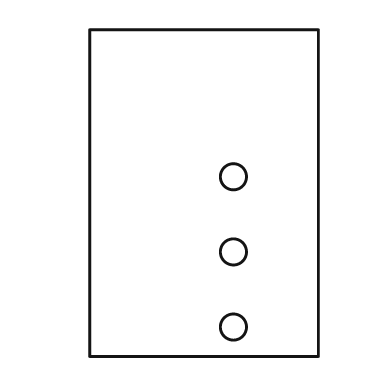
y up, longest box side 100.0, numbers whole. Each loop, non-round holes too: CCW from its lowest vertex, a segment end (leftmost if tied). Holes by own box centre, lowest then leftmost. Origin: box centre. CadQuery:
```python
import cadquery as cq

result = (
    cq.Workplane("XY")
    .moveTo(-35.0, -50.0)
    .lineTo(35.0, -50.0)
    .lineTo(35.0, 50.0)
    .lineTo(-35.0, 50.0)
    .close()
    .moveTo(9.0, -41.0)
    .circle(4.0)
    .moveTo(9.0, -18.0)
    .circle(4.0)
    .moveTo(9.0, 5.0)
    .circle(4.0)
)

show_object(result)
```